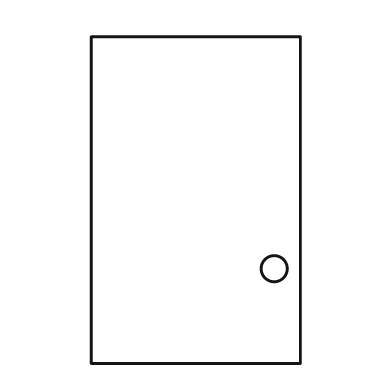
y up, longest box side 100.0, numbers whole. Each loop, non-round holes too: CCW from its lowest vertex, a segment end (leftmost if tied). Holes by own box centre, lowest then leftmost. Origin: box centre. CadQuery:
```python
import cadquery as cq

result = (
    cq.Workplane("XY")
    .moveTo(-32.0, -50.0)
    .lineTo(32.0, -50.0)
    .lineTo(32.0, 50.0)
    .lineTo(-32.0, 50.0)
    .close()
    .moveTo(24.0, -21.0)
    .circle(4.0)
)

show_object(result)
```